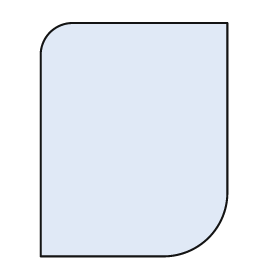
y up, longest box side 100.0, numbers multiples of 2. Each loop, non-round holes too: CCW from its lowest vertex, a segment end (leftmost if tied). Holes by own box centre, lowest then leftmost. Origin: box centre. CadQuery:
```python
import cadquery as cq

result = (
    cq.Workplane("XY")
    .moveTo(-40.0, -50.0)
    .lineTo(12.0, -50.0)
    .threePointArc((32.0, -42.0), (40.0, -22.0))
    .lineTo(40.0, 50.0)
    .lineTo(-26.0, 50.0)
    .threePointArc((-36.0, 46.0), (-40.0, 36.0))
    .close()
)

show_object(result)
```